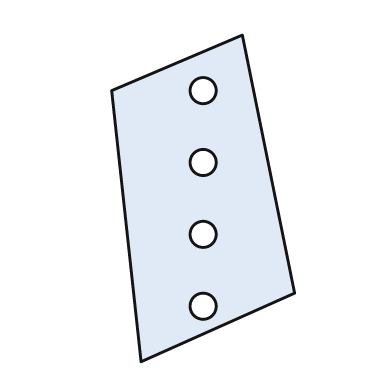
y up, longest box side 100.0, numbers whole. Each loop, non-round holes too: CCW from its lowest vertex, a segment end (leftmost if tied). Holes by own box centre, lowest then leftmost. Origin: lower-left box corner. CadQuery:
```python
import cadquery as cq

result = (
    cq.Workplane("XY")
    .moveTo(9.0, 0.0)
    .lineTo(56.0, 21.0)
    .lineTo(40.0, 100.0)
    .lineTo(0.0, 83.0)
    .close()
    .moveTo(28.0, 17.0)
    .circle(4.0)
    .moveTo(28.0, 39.0)
    .circle(4.0)
    .moveTo(28.0, 61.0)
    .circle(4.0)
    .moveTo(28.0, 83.0)
    .circle(4.0)
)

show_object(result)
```